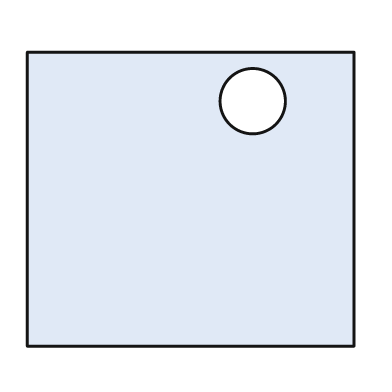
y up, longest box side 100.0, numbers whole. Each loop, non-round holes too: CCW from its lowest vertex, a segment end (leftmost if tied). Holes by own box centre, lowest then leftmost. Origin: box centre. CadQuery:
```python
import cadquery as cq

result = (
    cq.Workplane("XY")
    .moveTo(-50.0, -45.0)
    .lineTo(50.0, -45.0)
    .lineTo(50.0, 45.0)
    .lineTo(-50.0, 45.0)
    .close()
    .moveTo(19.0, 30.0)
    .circle(10.0)
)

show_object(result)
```